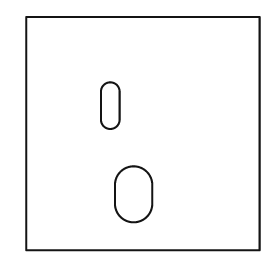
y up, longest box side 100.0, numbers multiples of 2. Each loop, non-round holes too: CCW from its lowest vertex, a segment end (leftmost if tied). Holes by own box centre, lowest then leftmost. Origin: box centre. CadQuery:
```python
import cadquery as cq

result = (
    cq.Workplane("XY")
    .moveTo(-50.0, -50.0)
    .lineTo(50.0, -50.0)
    .lineTo(50.0, 50.0)
    .lineTo(-50.0, 50.0)
    .close()
    .moveTo(-12.0, -30.0)
    .threePointArc((-4.0, -38.0), (4.0, -30.0))
    .lineTo(4.0, -22.0)
    .threePointArc((-4.0, -14.0), (-12.0, -22.0))
    .close()
    .moveTo(-18.0, 6.0)
    .threePointArc((-14.0, 2.0), (-10.0, 6.0))
    .lineTo(-10.0, 18.0)
    .threePointArc((-14.0, 22.0), (-18.0, 18.0))
    .close()
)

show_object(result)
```